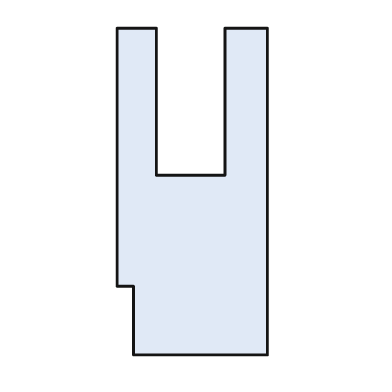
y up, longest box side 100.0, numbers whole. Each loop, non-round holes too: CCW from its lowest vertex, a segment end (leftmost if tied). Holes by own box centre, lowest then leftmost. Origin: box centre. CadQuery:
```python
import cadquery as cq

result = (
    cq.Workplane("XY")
    .moveTo(-18.0, -50.0)
    .lineTo(23.0, -50.0)
    .lineTo(23.0, 50.0)
    .lineTo(10.0, 50.0)
    .lineTo(10.0, 5.0)
    .lineTo(-11.0, 5.0)
    .lineTo(-11.0, 50.0)
    .lineTo(-23.0, 50.0)
    .lineTo(-23.0, -29.0)
    .lineTo(-18.0, -29.0)
    .close()
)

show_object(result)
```